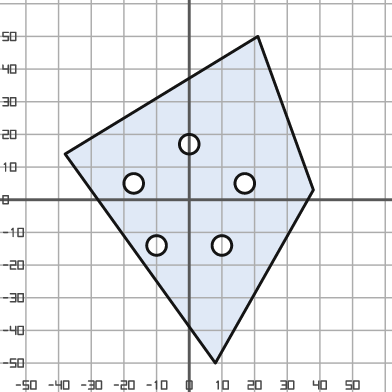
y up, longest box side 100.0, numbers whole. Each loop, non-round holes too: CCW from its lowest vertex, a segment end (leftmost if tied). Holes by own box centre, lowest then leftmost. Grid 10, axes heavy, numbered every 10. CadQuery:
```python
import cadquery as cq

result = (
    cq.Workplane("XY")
    .moveTo(8.0, -50.0)
    .lineTo(38.0, 3.0)
    .lineTo(21.0, 50.0)
    .lineTo(-38.0, 14.0)
    .close()
    .moveTo(-10.0, -14.0)
    .circle(3.0)
    .moveTo(10.0, -14.0)
    .circle(3.0)
    .moveTo(-17.0, 5.0)
    .circle(3.0)
    .moveTo(17.0, 5.0)
    .circle(3.0)
    .moveTo(0.0, 17.0)
    .circle(3.0)
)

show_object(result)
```